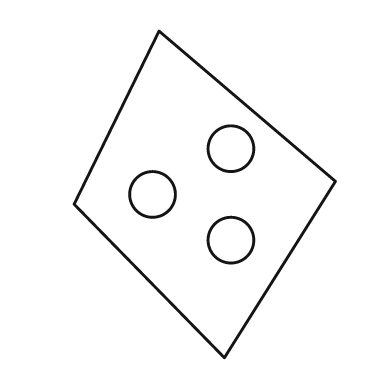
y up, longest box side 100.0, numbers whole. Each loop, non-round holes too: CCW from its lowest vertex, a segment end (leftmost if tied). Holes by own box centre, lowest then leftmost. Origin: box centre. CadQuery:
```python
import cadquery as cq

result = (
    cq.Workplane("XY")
    .moveTo(6.0, -50.0)
    .lineTo(40.0, 4.0)
    .lineTo(-14.0, 50.0)
    .lineTo(-40.0, -3.0)
    .close()
    .moveTo(8.0, -14.0)
    .circle(7.0)
    .moveTo(-16.0, 0.0)
    .circle(7.0)
    .moveTo(8.0, 14.0)
    .circle(7.0)
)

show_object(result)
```